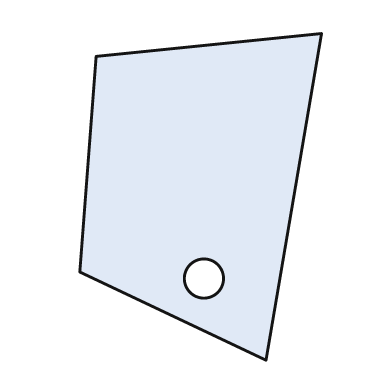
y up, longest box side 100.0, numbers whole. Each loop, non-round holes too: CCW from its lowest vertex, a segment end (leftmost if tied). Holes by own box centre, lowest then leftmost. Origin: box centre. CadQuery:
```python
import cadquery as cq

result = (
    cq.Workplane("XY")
    .moveTo(20.0, -50.0)
    .lineTo(37.0, 50.0)
    .lineTo(-32.0, 43.0)
    .lineTo(-37.0, -23.0)
    .close()
    .moveTo(1.0, -25.0)
    .circle(6.0)
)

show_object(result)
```